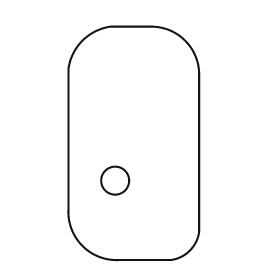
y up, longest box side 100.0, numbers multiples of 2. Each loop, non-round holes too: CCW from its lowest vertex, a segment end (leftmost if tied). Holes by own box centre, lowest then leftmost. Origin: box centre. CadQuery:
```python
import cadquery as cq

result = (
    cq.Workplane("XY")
    .moveTo(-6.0, -50.0)
    .lineTo(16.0, -50.0)
    .threePointArc((24.0, -46.0), (28.0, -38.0))
    .lineTo(28.0, 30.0)
    .threePointArc((22.0, 44.0), (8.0, 50.0))
    .lineTo(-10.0, 50.0)
    .threePointArc((-22.0, 44.0), (-28.0, 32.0))
    .lineTo(-28.0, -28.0)
    .threePointArc((-22.0, -44.0), (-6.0, -50.0))
    .close()
    .moveTo(-8.0, -16.0)
    .circle(6.0)
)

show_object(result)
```